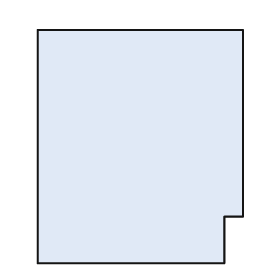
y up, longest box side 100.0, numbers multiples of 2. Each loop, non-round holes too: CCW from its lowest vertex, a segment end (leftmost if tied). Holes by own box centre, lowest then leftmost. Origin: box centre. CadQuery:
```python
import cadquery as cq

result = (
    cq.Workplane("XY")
    .moveTo(-44.0, -50.0)
    .lineTo(36.0, -50.0)
    .lineTo(36.0, -30.0)
    .lineTo(44.0, -30.0)
    .lineTo(44.0, 50.0)
    .lineTo(-44.0, 50.0)
    .close()
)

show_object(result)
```